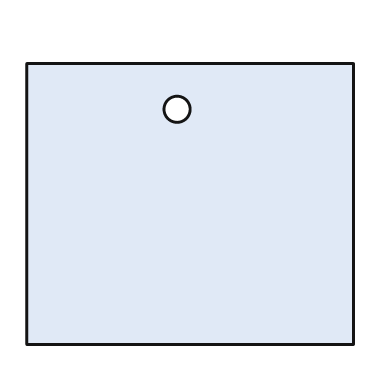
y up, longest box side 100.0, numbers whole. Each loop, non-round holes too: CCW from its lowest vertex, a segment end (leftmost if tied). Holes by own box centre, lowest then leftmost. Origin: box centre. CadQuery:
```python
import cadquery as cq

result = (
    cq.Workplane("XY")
    .moveTo(-50.0, -43.0)
    .lineTo(50.0, -43.0)
    .lineTo(50.0, 43.0)
    .lineTo(-50.0, 43.0)
    .close()
    .moveTo(-4.0, 29.0)
    .circle(4.0)
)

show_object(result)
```